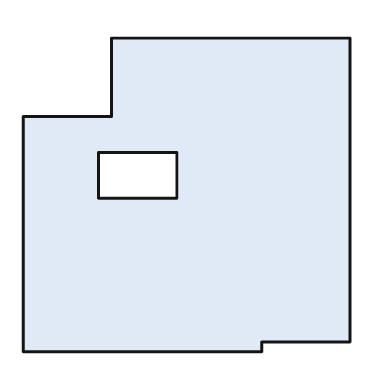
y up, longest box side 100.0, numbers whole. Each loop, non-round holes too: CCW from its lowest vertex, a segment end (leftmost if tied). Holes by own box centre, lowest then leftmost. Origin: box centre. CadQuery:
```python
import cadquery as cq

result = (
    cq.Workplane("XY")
    .moveTo(-50.0, -48.0)
    .lineTo(23.0, -48.0)
    .lineTo(23.0, -45.0)
    .lineTo(50.0, -45.0)
    .lineTo(50.0, 48.0)
    .lineTo(-23.0, 48.0)
    .lineTo(-23.0, 24.0)
    .lineTo(-50.0, 24.0)
    .close()
    .moveTo(-27.0, -1.0)
    .lineTo(-3.0, -1.0)
    .lineTo(-3.0, 13.0)
    .lineTo(-27.0, 13.0)
    .close()
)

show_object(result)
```